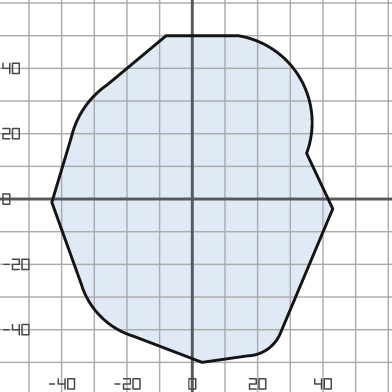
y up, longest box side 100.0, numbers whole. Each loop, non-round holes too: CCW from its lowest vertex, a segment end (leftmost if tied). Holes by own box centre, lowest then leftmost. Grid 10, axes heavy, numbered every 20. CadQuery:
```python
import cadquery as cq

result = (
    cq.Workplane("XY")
    .moveTo(3.0, -50.0)
    .lineTo(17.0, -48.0)
    .threePointArc((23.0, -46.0), (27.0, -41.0))
    .lineTo(43.0, -3.0)
    .lineTo(35.0, 14.0)
    .threePointArc((33.0, 37.0), (14.0, 50.0))
    .lineTo(-8.0, 50.0)
    .lineTo(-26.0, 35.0)
    .threePointArc((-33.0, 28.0), (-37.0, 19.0))
    .lineTo(-43.0, -1.0)
    .lineTo(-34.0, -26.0)
    .threePointArc((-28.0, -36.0), (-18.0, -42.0))
    .close()
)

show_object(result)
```